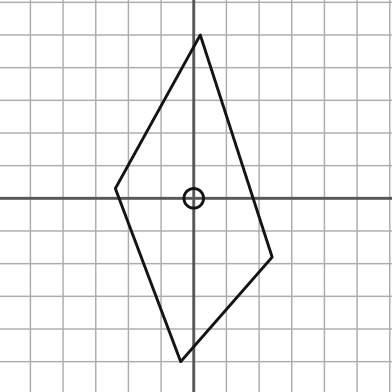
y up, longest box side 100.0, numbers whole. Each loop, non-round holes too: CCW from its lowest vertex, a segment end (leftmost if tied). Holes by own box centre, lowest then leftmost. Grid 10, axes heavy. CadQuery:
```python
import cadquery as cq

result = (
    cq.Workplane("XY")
    .moveTo(-4.0, -50.0)
    .lineTo(24.0, -18.0)
    .lineTo(2.0, 50.0)
    .lineTo(-24.0, 3.0)
    .close()
    .moveTo(0.0, 0.0)
    .circle(3.0)
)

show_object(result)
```